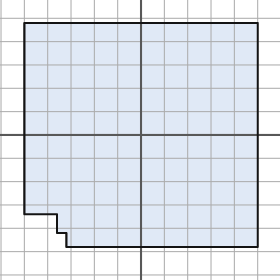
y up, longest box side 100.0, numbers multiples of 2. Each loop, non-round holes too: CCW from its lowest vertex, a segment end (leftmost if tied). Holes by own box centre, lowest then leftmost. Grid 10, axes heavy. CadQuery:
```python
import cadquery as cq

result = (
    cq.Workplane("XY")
    .moveTo(-32.0, -48.0)
    .lineTo(50.0, -48.0)
    .lineTo(50.0, 48.0)
    .lineTo(-50.0, 48.0)
    .lineTo(-50.0, -34.0)
    .lineTo(-36.0, -34.0)
    .lineTo(-36.0, -42.0)
    .lineTo(-32.0, -42.0)
    .close()
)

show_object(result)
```